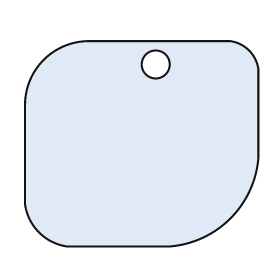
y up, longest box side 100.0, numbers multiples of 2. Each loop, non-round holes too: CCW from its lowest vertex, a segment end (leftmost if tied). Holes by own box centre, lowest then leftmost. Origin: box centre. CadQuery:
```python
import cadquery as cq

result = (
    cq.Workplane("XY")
    .moveTo(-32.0, -44.0)
    .lineTo(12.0, -44.0)
    .threePointArc((38.0, -32.0), (50.0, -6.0))
    .lineTo(50.0, 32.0)
    .threePointArc((46.0, 40.0), (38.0, 44.0))
    .lineTo(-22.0, 44.0)
    .threePointArc((-42.0, 36.0), (-50.0, 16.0))
    .lineTo(-50.0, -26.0)
    .threePointArc((-44.0, -38.0), (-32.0, -44.0))
    .close()
    .moveTo(6.0, 34.0)
    .circle(6.0)
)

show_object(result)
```